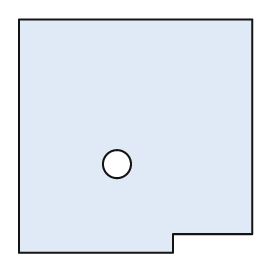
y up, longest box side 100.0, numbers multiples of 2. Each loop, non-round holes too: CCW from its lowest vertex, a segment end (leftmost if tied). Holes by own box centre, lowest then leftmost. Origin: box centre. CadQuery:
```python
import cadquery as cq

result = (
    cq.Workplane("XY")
    .moveTo(-50.0, -50.0)
    .lineTo(16.0, -50.0)
    .lineTo(16.0, -42.0)
    .lineTo(50.0, -42.0)
    .lineTo(50.0, 50.0)
    .lineTo(-50.0, 50.0)
    .close()
    .moveTo(-8.0, -12.0)
    .circle(6.0)
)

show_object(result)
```